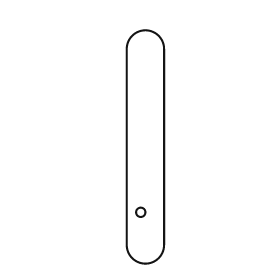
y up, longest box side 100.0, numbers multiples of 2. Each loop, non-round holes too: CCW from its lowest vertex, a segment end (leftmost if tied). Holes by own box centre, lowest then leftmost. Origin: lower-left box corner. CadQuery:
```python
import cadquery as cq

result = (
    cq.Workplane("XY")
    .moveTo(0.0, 8.0)
    .threePointArc((8.0, 0.0), (16.0, 8.0))
    .lineTo(16.0, 92.0)
    .threePointArc((8.0, 100.0), (0.0, 92.0))
    .close()
    .moveTo(6.0, 22.0)
    .circle(2.0)
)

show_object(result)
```